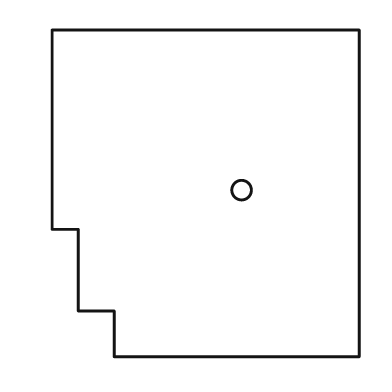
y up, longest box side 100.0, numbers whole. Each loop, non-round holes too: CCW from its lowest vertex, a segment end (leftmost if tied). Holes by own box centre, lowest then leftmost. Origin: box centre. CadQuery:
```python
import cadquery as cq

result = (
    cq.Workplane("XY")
    .moveTo(-28.0, -50.0)
    .lineTo(47.0, -50.0)
    .lineTo(47.0, 50.0)
    .lineTo(-47.0, 50.0)
    .lineTo(-47.0, -11.0)
    .lineTo(-39.0, -11.0)
    .lineTo(-39.0, -36.0)
    .lineTo(-28.0, -36.0)
    .close()
    .moveTo(11.0, 1.0)
    .circle(3.0)
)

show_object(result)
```